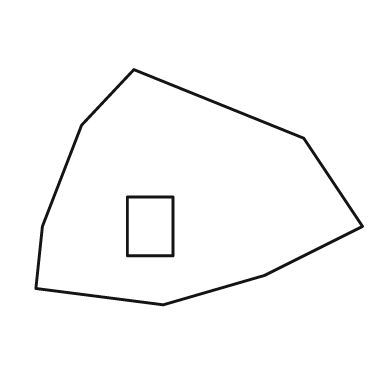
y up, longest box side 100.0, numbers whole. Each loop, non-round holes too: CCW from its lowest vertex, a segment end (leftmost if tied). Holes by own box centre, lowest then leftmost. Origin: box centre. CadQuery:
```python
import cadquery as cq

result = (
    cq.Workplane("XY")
    .moveTo(-11.0, -36.0)
    .lineTo(20.0, -27.0)
    .lineTo(50.0, -12.0)
    .lineTo(32.0, 15.0)
    .lineTo(-20.0, 36.0)
    .lineTo(-36.0, 19.0)
    .lineTo(-48.0, -12.0)
    .lineTo(-50.0, -31.0)
    .close()
    .moveTo(-22.0, -21.0)
    .lineTo(-8.0, -21.0)
    .lineTo(-8.0, -3.0)
    .lineTo(-22.0, -3.0)
    .close()
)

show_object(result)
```